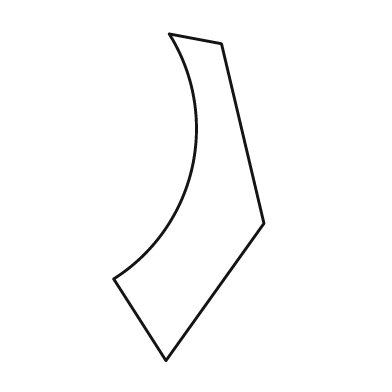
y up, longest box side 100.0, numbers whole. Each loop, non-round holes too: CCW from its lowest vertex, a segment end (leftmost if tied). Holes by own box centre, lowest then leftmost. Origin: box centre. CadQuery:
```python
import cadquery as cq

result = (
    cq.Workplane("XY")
    .moveTo(-7.0, -50.0)
    .lineTo(23.0, -8.0)
    .lineTo(10.0, 47.0)
    .lineTo(-6.0, 50.0)
    .threePointArc((1.0, 9.0), (-23.0, -25.0))
    .close()
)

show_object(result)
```